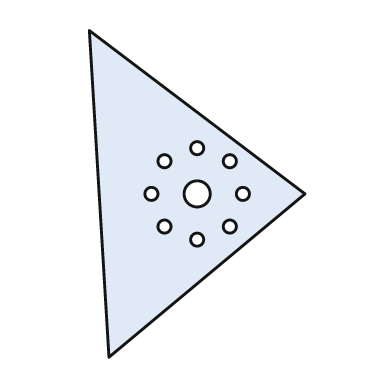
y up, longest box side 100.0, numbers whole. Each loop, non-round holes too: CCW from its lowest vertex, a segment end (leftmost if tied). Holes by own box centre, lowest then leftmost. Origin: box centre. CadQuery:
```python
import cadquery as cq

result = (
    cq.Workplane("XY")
    .moveTo(-27.0, -50.0)
    .lineTo(33.0, 0.0)
    .lineTo(-33.0, 50.0)
    .close()
    .moveTo(0.0, -14.0)
    .circle(2.0)
    .moveTo(-10.0, -10.0)
    .circle(2.0)
    .moveTo(10.0, -10.0)
    .circle(2.0)
    .moveTo(-14.0, 0.0)
    .circle(2.0)
    .moveTo(0.0, 0.0)
    .circle(4.0)
    .moveTo(14.0, 0.0)
    .circle(2.0)
    .moveTo(-10.0, 10.0)
    .circle(2.0)
    .moveTo(10.0, 10.0)
    .circle(2.0)
    .moveTo(0.0, 14.0)
    .circle(2.0)
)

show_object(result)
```